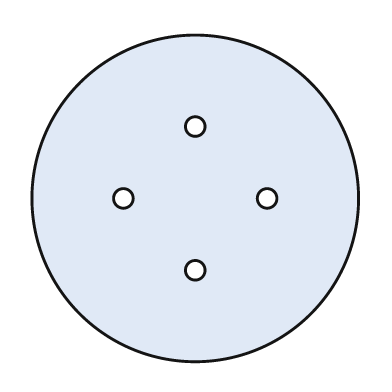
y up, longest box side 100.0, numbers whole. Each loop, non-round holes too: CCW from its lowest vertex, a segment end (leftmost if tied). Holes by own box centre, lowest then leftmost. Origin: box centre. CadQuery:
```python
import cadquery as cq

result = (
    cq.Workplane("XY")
    .moveTo(0.0, 0.0)
    .circle(50.0)
    .moveTo(0.0, -22.0)
    .circle(3.0)
    .moveTo(-22.0, 0.0)
    .circle(3.0)
    .moveTo(22.0, 0.0)
    .circle(3.0)
    .moveTo(0.0, 22.0)
    .circle(3.0)
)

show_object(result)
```